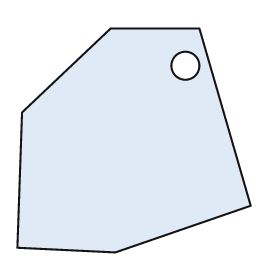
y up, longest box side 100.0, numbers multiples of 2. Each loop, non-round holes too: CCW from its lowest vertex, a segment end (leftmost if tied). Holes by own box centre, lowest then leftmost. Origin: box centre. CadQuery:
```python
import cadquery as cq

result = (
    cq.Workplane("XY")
    .moveTo(-8.0, -48.0)
    .lineTo(50.0, -28.0)
    .lineTo(28.0, 48.0)
    .lineTo(-10.0, 48.0)
    .lineTo(-48.0, 12.0)
    .lineTo(-50.0, -46.0)
    .close()
    .moveTo(22.0, 32.0)
    .circle(6.0)
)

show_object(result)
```